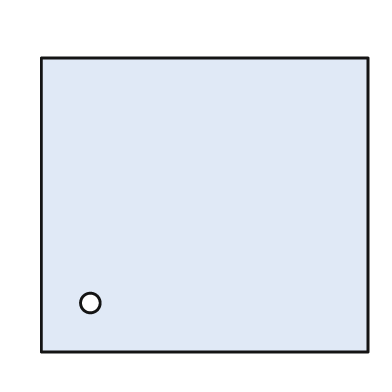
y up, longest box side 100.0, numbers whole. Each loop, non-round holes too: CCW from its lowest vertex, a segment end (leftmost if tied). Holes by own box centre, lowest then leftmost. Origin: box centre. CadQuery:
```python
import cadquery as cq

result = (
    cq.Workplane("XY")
    .moveTo(-50.0, -45.0)
    .lineTo(50.0, -45.0)
    .lineTo(50.0, 45.0)
    .lineTo(-50.0, 45.0)
    .close()
    .moveTo(-35.0, -30.0)
    .circle(3.0)
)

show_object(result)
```